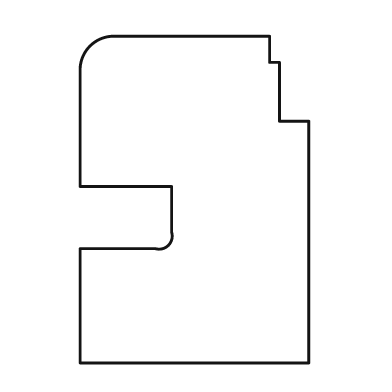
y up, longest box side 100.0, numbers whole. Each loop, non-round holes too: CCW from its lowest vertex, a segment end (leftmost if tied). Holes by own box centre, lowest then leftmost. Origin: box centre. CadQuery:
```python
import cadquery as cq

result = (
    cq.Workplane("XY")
    .moveTo(-35.0, -50.0)
    .lineTo(35.0, -50.0)
    .lineTo(35.0, 24.0)
    .lineTo(26.0, 24.0)
    .lineTo(26.0, 42.0)
    .lineTo(23.0, 42.0)
    .lineTo(23.0, 50.0)
    .lineTo(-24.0, 50.0)
    .threePointArc((-32.0, 47.0), (-35.0, 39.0))
    .lineTo(-35.0, 4.0)
    .lineTo(-7.0, 4.0)
    .lineTo(-7.0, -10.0)
    .threePointArc((-8.0, -14.0), (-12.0, -15.0))
    .lineTo(-35.0, -15.0)
    .close()
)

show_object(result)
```